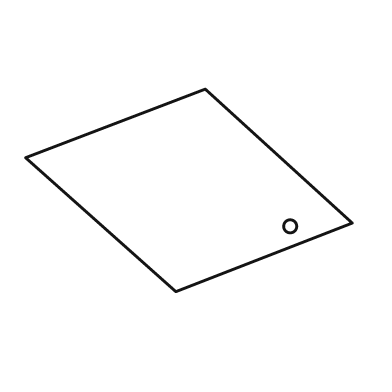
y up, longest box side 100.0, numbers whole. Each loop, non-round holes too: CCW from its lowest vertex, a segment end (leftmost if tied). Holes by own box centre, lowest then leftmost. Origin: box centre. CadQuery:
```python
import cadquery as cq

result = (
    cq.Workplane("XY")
    .moveTo(-4.0, -31.0)
    .lineTo(50.0, -10.0)
    .lineTo(5.0, 31.0)
    .lineTo(-50.0, 10.0)
    .close()
    .moveTo(31.0, -11.0)
    .circle(2.0)
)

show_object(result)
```